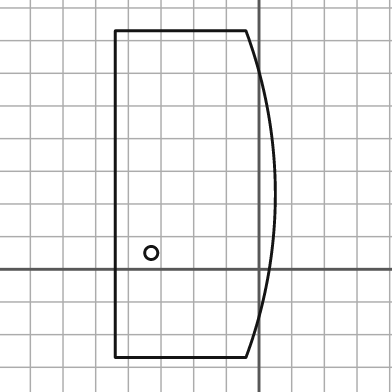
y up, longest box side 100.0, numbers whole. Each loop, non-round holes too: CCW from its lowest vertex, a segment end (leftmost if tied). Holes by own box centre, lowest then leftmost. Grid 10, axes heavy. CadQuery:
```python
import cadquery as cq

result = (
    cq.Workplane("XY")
    .moveTo(-44.0, -27.0)
    .lineTo(-4.0, -27.0)
    .threePointArc((5.0, 23.0), (-4.0, 73.0))
    .lineTo(-44.0, 73.0)
    .close()
    .moveTo(-33.0, 5.0)
    .circle(2.0)
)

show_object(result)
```